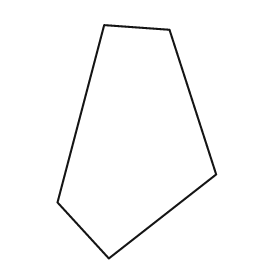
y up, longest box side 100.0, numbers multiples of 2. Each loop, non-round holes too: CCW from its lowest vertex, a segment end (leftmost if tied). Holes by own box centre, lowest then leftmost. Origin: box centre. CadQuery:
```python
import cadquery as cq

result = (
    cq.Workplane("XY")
    .moveTo(-12.0, -50.0)
    .lineTo(34.0, -14.0)
    .lineTo(14.0, 48.0)
    .lineTo(-14.0, 50.0)
    .lineTo(-34.0, -26.0)
    .close()
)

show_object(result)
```